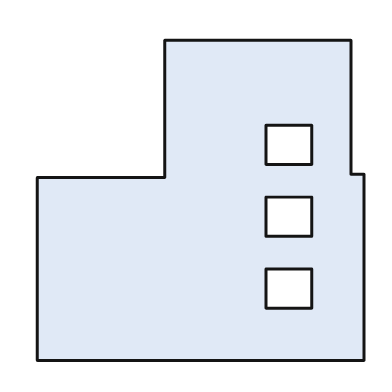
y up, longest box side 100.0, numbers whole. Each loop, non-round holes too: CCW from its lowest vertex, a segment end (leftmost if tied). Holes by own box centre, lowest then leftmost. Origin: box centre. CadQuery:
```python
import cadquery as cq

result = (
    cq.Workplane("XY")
    .moveTo(-50.0, -49.0)
    .lineTo(50.0, -49.0)
    .lineTo(50.0, 8.0)
    .lineTo(46.0, 8.0)
    .lineTo(46.0, 49.0)
    .lineTo(-11.0, 49.0)
    .lineTo(-11.0, 7.0)
    .lineTo(-50.0, 7.0)
    .close()
    .moveTo(20.0, -33.0)
    .lineTo(34.0, -33.0)
    .lineTo(34.0, -21.0)
    .lineTo(20.0, -21.0)
    .close()
    .moveTo(20.0, -11.0)
    .lineTo(34.0, -11.0)
    .lineTo(34.0, 1.0)
    .lineTo(20.0, 1.0)
    .close()
    .moveTo(20.0, 11.0)
    .lineTo(34.0, 11.0)
    .lineTo(34.0, 23.0)
    .lineTo(20.0, 23.0)
    .close()
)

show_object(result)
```